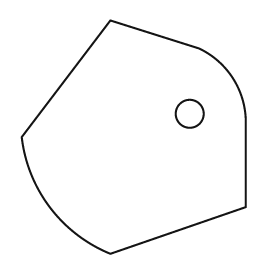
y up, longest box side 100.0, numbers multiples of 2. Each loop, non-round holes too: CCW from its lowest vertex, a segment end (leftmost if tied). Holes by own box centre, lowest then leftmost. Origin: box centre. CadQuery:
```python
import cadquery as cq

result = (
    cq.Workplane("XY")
    .moveTo(-10.0, -50.0)
    .lineTo(48.0, -30.0)
    .lineTo(48.0, 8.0)
    .threePointArc((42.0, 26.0), (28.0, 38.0))
    .lineTo(-10.0, 50.0)
    .lineTo(-48.0, 0.0)
    .threePointArc((-36.0, -30.0), (-10.0, -50.0))
    .close()
    .moveTo(24.0, 10.0)
    .circle(6.0)
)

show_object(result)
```